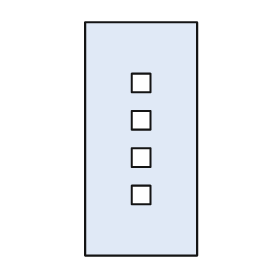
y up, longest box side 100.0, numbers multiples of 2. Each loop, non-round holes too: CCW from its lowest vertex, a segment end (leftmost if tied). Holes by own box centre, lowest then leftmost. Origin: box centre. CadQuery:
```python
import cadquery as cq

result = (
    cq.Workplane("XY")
    .moveTo(-24.0, -50.0)
    .lineTo(24.0, -50.0)
    .lineTo(24.0, 50.0)
    .lineTo(-24.0, 50.0)
    .close()
    .moveTo(-4.0, -28.0)
    .lineTo(4.0, -28.0)
    .lineTo(4.0, -20.0)
    .lineTo(-4.0, -20.0)
    .close()
    .moveTo(-4.0, -12.0)
    .lineTo(4.0, -12.0)
    .lineTo(4.0, -4.0)
    .lineTo(-4.0, -4.0)
    .close()
    .moveTo(-4.0, 4.0)
    .lineTo(4.0, 4.0)
    .lineTo(4.0, 12.0)
    .lineTo(-4.0, 12.0)
    .close()
    .moveTo(-4.0, 20.0)
    .lineTo(4.0, 20.0)
    .lineTo(4.0, 28.0)
    .lineTo(-4.0, 28.0)
    .close()
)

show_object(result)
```